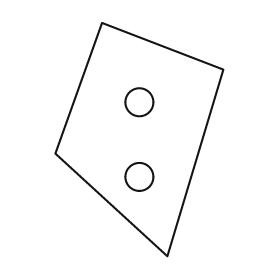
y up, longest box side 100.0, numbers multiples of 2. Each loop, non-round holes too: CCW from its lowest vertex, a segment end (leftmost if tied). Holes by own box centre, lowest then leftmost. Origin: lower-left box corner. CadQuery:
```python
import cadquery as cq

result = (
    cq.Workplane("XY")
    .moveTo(48.0, 0.0)
    .lineTo(72.0, 80.0)
    .lineTo(20.0, 100.0)
    .lineTo(0.0, 44.0)
    .close()
    .moveTo(36.0, 34.0)
    .circle(6.0)
    .moveTo(36.0, 66.0)
    .circle(6.0)
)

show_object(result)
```